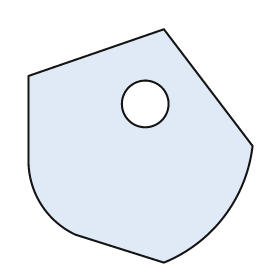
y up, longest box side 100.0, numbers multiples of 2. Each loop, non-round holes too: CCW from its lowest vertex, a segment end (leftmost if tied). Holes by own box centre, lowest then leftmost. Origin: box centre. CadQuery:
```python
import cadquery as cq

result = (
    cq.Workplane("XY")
    .moveTo(10.0, -50.0)
    .threePointArc((36.0, -30.0), (48.0, 0.0))
    .lineTo(10.0, 50.0)
    .lineTo(-48.0, 30.0)
    .lineTo(-48.0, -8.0)
    .threePointArc((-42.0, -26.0), (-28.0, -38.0))
    .close()
    .moveTo(2.0, 18.0)
    .circle(10.0)
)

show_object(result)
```